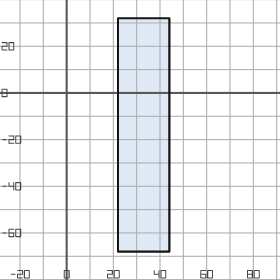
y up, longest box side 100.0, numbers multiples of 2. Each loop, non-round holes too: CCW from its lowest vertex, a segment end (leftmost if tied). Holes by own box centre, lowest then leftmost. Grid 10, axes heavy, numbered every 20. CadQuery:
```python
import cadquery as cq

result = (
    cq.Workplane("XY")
    .moveTo(22.0, -68.0)
    .lineTo(44.0, -68.0)
    .lineTo(44.0, 32.0)
    .lineTo(22.0, 32.0)
    .close()
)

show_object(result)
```